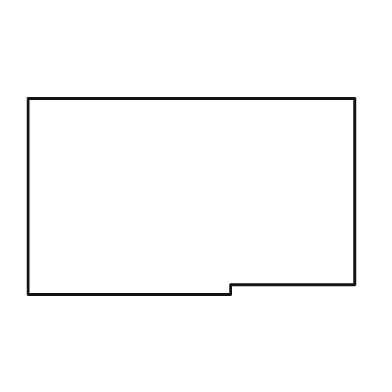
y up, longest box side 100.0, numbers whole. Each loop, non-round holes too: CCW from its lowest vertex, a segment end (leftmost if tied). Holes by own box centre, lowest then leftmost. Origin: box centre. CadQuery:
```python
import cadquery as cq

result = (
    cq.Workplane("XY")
    .moveTo(-50.0, -30.0)
    .lineTo(12.0, -30.0)
    .lineTo(12.0, -27.0)
    .lineTo(50.0, -27.0)
    .lineTo(50.0, 30.0)
    .lineTo(-50.0, 30.0)
    .close()
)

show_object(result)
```